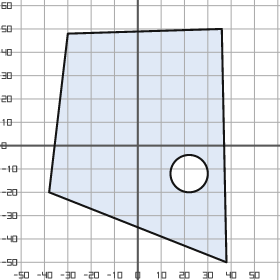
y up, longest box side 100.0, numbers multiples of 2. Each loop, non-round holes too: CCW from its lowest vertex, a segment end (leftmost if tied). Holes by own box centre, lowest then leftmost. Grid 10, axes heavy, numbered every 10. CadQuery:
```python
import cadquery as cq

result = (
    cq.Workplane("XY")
    .moveTo(38.0, -50.0)
    .lineTo(36.0, 50.0)
    .lineTo(-30.0, 48.0)
    .lineTo(-38.0, -20.0)
    .close()
    .moveTo(22.0, -12.0)
    .circle(8.0)
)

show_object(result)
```